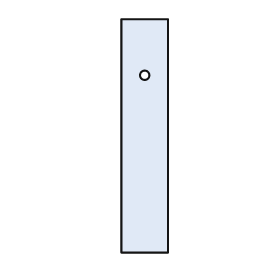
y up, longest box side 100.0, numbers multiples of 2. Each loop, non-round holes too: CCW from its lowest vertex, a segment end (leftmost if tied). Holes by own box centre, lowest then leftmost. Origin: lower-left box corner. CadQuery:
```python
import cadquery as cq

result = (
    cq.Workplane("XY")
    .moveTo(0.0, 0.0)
    .lineTo(20.0, 0.0)
    .lineTo(20.0, 100.0)
    .lineTo(0.0, 100.0)
    .close()
    .moveTo(10.0, 76.0)
    .circle(2.0)
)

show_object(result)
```